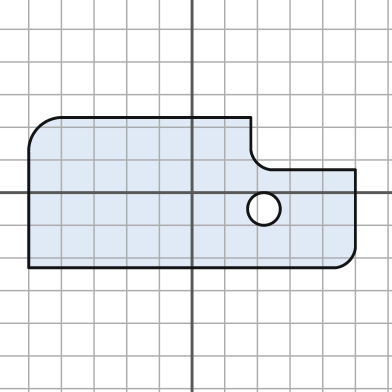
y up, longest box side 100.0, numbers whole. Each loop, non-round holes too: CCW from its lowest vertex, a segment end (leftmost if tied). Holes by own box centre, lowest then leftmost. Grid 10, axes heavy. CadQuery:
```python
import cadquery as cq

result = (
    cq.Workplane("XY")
    .moveTo(-50.0, -23.0)
    .lineTo(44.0, -23.0)
    .threePointArc((48.0, -21.0), (50.0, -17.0))
    .lineTo(50.0, 7.0)
    .lineTo(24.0, 7.0)
    .threePointArc((20.0, 9.0), (18.0, 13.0))
    .lineTo(18.0, 23.0)
    .lineTo(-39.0, 23.0)
    .threePointArc((-47.0, 20.0), (-50.0, 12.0))
    .close()
    .moveTo(22.0, -5.0)
    .circle(5.0)
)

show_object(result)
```